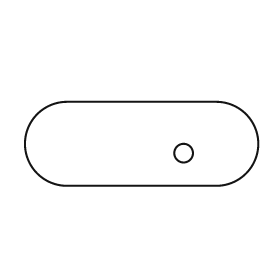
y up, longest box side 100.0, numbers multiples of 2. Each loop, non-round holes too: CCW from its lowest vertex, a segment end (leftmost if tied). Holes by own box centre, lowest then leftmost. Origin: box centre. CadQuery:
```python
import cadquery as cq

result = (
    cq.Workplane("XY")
    .moveTo(-32.0, -18.0)
    .lineTo(32.0, -18.0)
    .threePointArc((50.0, 0.0), (32.0, 18.0))
    .lineTo(-32.0, 18.0)
    .threePointArc((-50.0, 0.0), (-32.0, -18.0))
    .close()
    .moveTo(18.0, -4.0)
    .circle(4.0)
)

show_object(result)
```